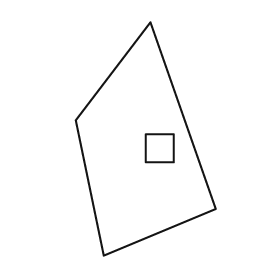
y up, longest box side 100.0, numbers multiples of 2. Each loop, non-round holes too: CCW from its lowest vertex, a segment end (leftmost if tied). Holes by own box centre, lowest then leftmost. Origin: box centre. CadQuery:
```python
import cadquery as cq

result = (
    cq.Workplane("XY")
    .moveTo(-18.0, -50.0)
    .lineTo(30.0, -30.0)
    .lineTo(2.0, 50.0)
    .lineTo(-30.0, 8.0)
    .close()
    .moveTo(0.0, -10.0)
    .lineTo(12.0, -10.0)
    .lineTo(12.0, 2.0)
    .lineTo(0.0, 2.0)
    .close()
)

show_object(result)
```